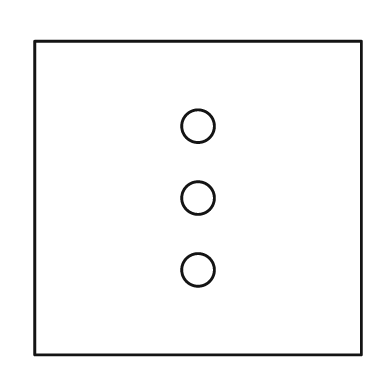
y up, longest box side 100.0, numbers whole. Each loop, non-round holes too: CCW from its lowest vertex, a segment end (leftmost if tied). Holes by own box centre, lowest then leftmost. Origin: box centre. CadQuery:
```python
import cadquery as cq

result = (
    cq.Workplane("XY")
    .moveTo(-50.0, -48.0)
    .lineTo(50.0, -48.0)
    .lineTo(50.0, 48.0)
    .lineTo(-50.0, 48.0)
    .close()
    .moveTo(0.0, -22.0)
    .circle(5.0)
    .moveTo(0.0, 0.0)
    .circle(5.0)
    .moveTo(0.0, 22.0)
    .circle(5.0)
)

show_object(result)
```